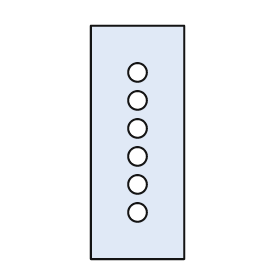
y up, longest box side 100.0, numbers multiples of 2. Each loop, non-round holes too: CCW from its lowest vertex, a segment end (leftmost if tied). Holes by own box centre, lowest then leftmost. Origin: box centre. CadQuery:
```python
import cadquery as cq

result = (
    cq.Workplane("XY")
    .moveTo(-20.0, -50.0)
    .lineTo(20.0, -50.0)
    .lineTo(20.0, 50.0)
    .lineTo(-20.0, 50.0)
    .close()
    .moveTo(0.0, -30.0)
    .circle(4.0)
    .moveTo(0.0, -18.0)
    .circle(4.0)
    .moveTo(0.0, -6.0)
    .circle(4.0)
    .moveTo(0.0, 6.0)
    .circle(4.0)
    .moveTo(0.0, 18.0)
    .circle(4.0)
    .moveTo(0.0, 30.0)
    .circle(4.0)
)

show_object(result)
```